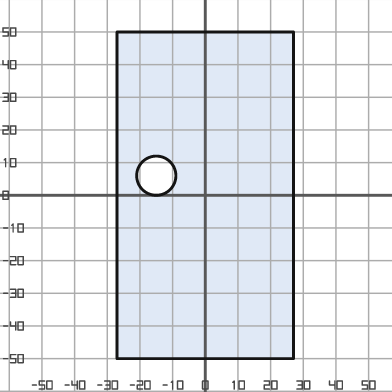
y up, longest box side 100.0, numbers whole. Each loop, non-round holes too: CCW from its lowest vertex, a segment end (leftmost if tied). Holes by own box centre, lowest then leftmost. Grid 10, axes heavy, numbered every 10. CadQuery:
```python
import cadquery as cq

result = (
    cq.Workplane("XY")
    .moveTo(-27.0, -50.0)
    .lineTo(27.0, -50.0)
    .lineTo(27.0, 50.0)
    .lineTo(-27.0, 50.0)
    .close()
    .moveTo(-15.0, 6.0)
    .circle(6.0)
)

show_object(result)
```